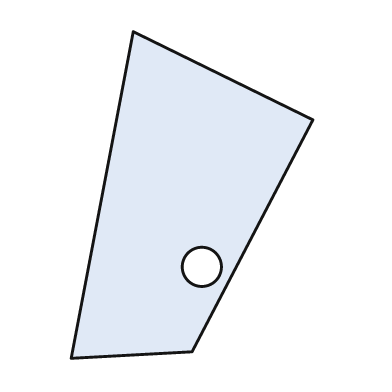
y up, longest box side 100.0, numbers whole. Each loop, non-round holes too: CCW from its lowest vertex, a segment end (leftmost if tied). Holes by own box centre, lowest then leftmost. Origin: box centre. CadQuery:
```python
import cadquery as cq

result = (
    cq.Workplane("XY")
    .moveTo(-37.0, -50.0)
    .lineTo(0.0, -48.0)
    .lineTo(37.0, 23.0)
    .lineTo(-18.0, 50.0)
    .close()
    .moveTo(3.0, -22.0)
    .circle(6.0)
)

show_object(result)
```